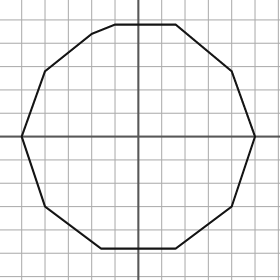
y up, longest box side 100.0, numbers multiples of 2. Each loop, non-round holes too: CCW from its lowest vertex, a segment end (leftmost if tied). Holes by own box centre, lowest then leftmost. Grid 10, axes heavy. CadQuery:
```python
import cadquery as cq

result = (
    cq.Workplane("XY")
    .moveTo(-16.0, -48.0)
    .lineTo(16.0, -48.0)
    .lineTo(40.0, -30.0)
    .lineTo(50.0, 0.0)
    .lineTo(40.0, 28.0)
    .lineTo(16.0, 48.0)
    .lineTo(-10.0, 48.0)
    .lineTo(-20.0, 44.0)
    .lineTo(-40.0, 28.0)
    .lineTo(-50.0, 0.0)
    .lineTo(-40.0, -30.0)
    .close()
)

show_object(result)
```